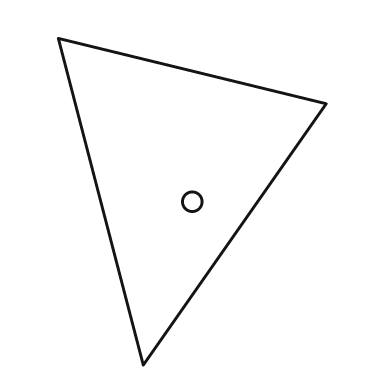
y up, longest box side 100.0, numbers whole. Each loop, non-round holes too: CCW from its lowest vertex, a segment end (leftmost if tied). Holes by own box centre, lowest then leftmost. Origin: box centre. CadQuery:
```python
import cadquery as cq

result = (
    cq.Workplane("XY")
    .moveTo(-15.0, -50.0)
    .lineTo(41.0, 30.0)
    .lineTo(-41.0, 50.0)
    .close()
    .moveTo(0.0, 0.0)
    .circle(3.0)
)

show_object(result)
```